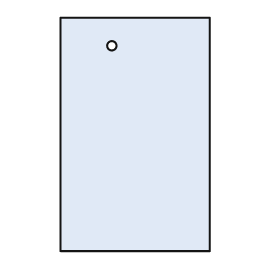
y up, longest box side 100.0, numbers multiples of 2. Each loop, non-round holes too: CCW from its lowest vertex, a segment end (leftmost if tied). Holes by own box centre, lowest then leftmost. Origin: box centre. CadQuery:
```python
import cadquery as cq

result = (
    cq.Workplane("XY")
    .moveTo(-32.0, -50.0)
    .lineTo(32.0, -50.0)
    .lineTo(32.0, 50.0)
    .lineTo(-32.0, 50.0)
    .close()
    .moveTo(-10.0, 38.0)
    .circle(2.0)
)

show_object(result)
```